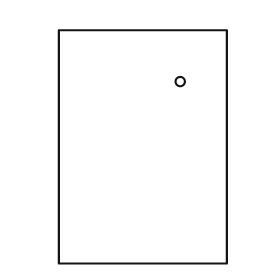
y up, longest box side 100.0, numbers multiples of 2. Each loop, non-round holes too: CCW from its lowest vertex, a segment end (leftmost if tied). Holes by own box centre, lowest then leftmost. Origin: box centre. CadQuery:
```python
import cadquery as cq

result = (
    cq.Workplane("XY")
    .moveTo(-36.0, -50.0)
    .lineTo(36.0, -50.0)
    .lineTo(36.0, 50.0)
    .lineTo(-36.0, 50.0)
    .close()
    .moveTo(16.0, 28.0)
    .circle(2.0)
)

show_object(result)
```